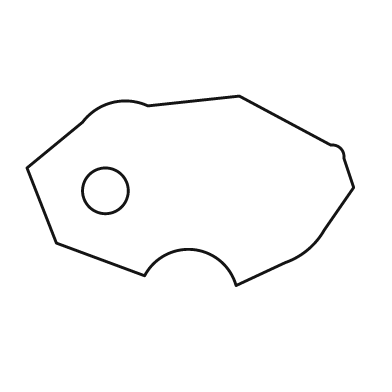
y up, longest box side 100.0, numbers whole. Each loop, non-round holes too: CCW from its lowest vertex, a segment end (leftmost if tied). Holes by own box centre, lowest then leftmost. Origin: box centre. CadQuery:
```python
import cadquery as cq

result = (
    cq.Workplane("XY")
    .moveTo(14.0, -29.0)
    .lineTo(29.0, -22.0)
    .threePointArc((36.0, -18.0), (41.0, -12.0))
    .lineTo(50.0, 1.0)
    .lineTo(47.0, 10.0)
    .threePointArc((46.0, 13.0), (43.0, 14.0))
    .lineTo(15.0, 29.0)
    .lineTo(-13.0, 26.0)
    .threePointArc((-24.0, 27.0), (-33.0, 21.0))
    .lineTo(-50.0, 7.0)
    .lineTo(-41.0, -16.0)
    .lineTo(-14.0, -26.0)
    .threePointArc((1.0, -18.0), (14.0, -29.0))
    .close()
    .moveTo(-26.0, 0.0)
    .circle(7.0)
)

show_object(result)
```